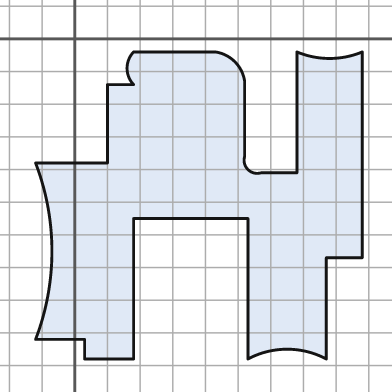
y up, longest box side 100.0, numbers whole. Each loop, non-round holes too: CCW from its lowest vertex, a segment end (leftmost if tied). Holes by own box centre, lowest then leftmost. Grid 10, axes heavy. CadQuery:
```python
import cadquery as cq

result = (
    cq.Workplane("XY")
    .moveTo(3.0, -98.0)
    .lineTo(18.0, -98.0)
    .lineTo(18.0, -55.0)
    .lineTo(53.0, -55.0)
    .lineTo(53.0, -98.0)
    .threePointArc((65.0, -95.0), (77.0, -98.0))
    .lineTo(77.0, -67.0)
    .lineTo(88.0, -67.0)
    .lineTo(88.0, -4.0)
    .threePointArc((78.0, -6.0), (68.0, -4.0))
    .lineTo(68.0, -41.0)
    .lineTo(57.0, -41.0)
    .threePointArc((53.0, -40.0), (52.0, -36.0))
    .lineTo(52.0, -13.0)
    .threePointArc((49.0, -7.0), (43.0, -4.0))
    .lineTo(18.0, -4.0)
    .threePointArc((16.0, -9.0), (18.0, -14.0))
    .lineTo(10.0, -14.0)
    .lineTo(10.0, -38.0)
    .lineTo(-12.0, -38.0)
    .threePointArc((-7.0, -65.0), (-12.0, -92.0))
    .lineTo(3.0, -92.0)
    .close()
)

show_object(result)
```